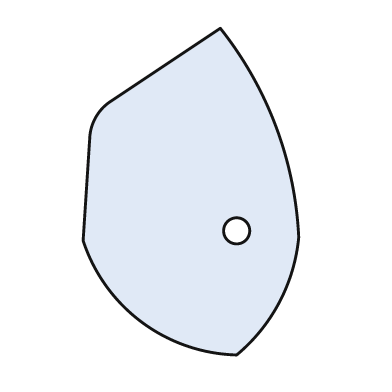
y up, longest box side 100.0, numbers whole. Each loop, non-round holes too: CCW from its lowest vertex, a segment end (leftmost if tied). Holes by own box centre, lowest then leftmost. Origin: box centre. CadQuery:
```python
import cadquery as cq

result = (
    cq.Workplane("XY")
    .moveTo(14.0, -50.0)
    .threePointArc((27.0, -34.0), (33.0, -14.0))
    .threePointArc((26.0, 20.0), (9.0, 50.0))
    .lineTo(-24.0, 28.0)
    .threePointArc((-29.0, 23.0), (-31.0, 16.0))
    .lineTo(-33.0, -15.0)
    .threePointArc((-15.0, -40.0), (14.0, -50.0))
    .close()
    .moveTo(14.0, -12.0)
    .circle(4.0)
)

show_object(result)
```